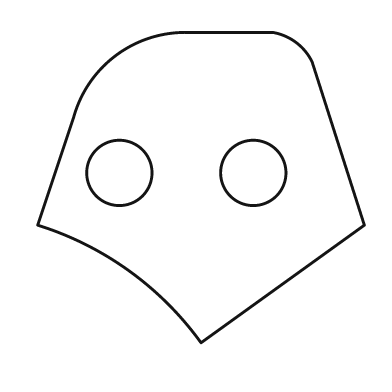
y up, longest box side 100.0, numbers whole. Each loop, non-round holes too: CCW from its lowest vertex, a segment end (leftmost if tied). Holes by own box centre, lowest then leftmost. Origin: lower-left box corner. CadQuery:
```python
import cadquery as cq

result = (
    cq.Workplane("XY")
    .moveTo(50.0, 0.0)
    .lineTo(100.0, 36.0)
    .lineTo(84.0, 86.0)
    .threePointArc((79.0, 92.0), (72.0, 95.0))
    .lineTo(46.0, 95.0)
    .threePointArc((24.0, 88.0), (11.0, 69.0))
    .lineTo(0.0, 36.0)
    .threePointArc((28.0, 22.0), (50.0, 0.0))
    .close()
    .moveTo(25.0, 52.0)
    .circle(10.0)
    .moveTo(66.0, 52.0)
    .circle(10.0)
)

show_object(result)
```